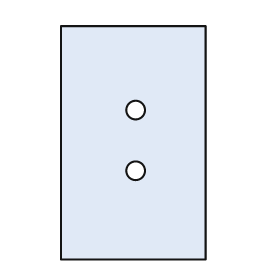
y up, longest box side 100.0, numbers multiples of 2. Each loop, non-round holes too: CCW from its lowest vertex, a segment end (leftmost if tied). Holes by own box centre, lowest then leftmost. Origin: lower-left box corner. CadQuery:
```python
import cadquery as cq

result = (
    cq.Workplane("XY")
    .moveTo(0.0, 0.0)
    .lineTo(62.0, 0.0)
    .lineTo(62.0, 100.0)
    .lineTo(0.0, 100.0)
    .close()
    .moveTo(32.0, 38.0)
    .circle(4.0)
    .moveTo(32.0, 64.0)
    .circle(4.0)
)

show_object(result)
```